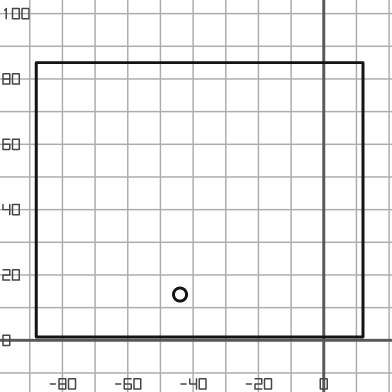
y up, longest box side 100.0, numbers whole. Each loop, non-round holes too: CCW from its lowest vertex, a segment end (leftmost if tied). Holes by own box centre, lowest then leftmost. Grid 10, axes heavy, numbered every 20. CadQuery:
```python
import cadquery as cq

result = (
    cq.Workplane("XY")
    .moveTo(-88.0, 1.0)
    .lineTo(12.0, 1.0)
    .lineTo(12.0, 85.0)
    .lineTo(-88.0, 85.0)
    .close()
    .moveTo(-44.0, 14.0)
    .circle(2.0)
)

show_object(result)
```